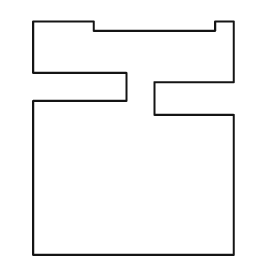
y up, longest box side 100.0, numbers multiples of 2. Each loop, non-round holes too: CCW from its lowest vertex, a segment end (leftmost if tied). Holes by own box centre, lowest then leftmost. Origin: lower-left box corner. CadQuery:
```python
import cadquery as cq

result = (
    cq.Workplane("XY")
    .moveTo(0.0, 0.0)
    .lineTo(86.0, 0.0)
    .lineTo(86.0, 60.0)
    .lineTo(52.0, 60.0)
    .lineTo(52.0, 74.0)
    .lineTo(86.0, 74.0)
    .lineTo(86.0, 100.0)
    .lineTo(78.0, 100.0)
    .lineTo(78.0, 96.0)
    .lineTo(26.0, 96.0)
    .lineTo(26.0, 100.0)
    .lineTo(0.0, 100.0)
    .lineTo(0.0, 78.0)
    .lineTo(40.0, 78.0)
    .lineTo(40.0, 66.0)
    .lineTo(0.0, 66.0)
    .close()
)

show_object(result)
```